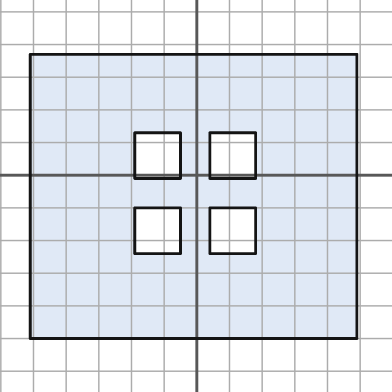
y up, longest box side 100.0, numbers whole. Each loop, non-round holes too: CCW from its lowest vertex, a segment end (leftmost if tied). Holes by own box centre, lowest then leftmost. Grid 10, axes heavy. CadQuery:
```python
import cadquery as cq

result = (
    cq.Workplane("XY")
    .moveTo(-51.0, -50.0)
    .lineTo(49.0, -50.0)
    .lineTo(49.0, 37.0)
    .lineTo(-51.0, 37.0)
    .close()
    .moveTo(-19.0, -24.0)
    .lineTo(-5.0, -24.0)
    .lineTo(-5.0, -10.0)
    .lineTo(-19.0, -10.0)
    .close()
    .moveTo(4.0, -24.0)
    .lineTo(18.0, -24.0)
    .lineTo(18.0, -10.0)
    .lineTo(4.0, -10.0)
    .close()
    .moveTo(-19.0, -1.0)
    .lineTo(-5.0, -1.0)
    .lineTo(-5.0, 13.0)
    .lineTo(-19.0, 13.0)
    .close()
    .moveTo(4.0, -1.0)
    .lineTo(18.0, -1.0)
    .lineTo(18.0, 13.0)
    .lineTo(4.0, 13.0)
    .close()
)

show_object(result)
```